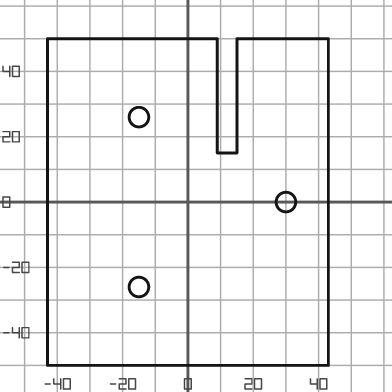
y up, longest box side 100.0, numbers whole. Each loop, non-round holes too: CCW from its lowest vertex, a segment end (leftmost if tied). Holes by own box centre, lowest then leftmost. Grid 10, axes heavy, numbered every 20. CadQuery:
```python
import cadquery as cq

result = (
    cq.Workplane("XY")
    .moveTo(-43.0, -50.0)
    .lineTo(43.0, -50.0)
    .lineTo(43.0, 50.0)
    .lineTo(15.0, 50.0)
    .lineTo(15.0, 15.0)
    .lineTo(9.0, 15.0)
    .lineTo(9.0, 50.0)
    .lineTo(-43.0, 50.0)
    .close()
    .moveTo(-15.0, -26.0)
    .circle(3.0)
    .moveTo(30.0, 0.0)
    .circle(3.0)
    .moveTo(-15.0, 26.0)
    .circle(3.0)
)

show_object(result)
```